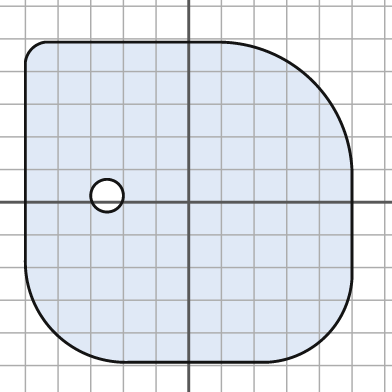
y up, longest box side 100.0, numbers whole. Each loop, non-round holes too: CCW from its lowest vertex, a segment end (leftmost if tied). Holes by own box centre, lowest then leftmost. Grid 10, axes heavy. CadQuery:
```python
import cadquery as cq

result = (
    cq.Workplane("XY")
    .moveTo(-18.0, -49.0)
    .lineTo(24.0, -49.0)
    .threePointArc((42.0, -41.0), (50.0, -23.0))
    .lineTo(50.0, 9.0)
    .threePointArc((38.0, 37.0), (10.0, 49.0))
    .lineTo(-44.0, 49.0)
    .threePointArc((-48.0, 47.0), (-50.0, 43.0))
    .lineTo(-50.0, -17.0)
    .threePointArc((-41.0, -40.0), (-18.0, -49.0))
    .close()
    .moveTo(-25.0, 2.0)
    .circle(5.0)
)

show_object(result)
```